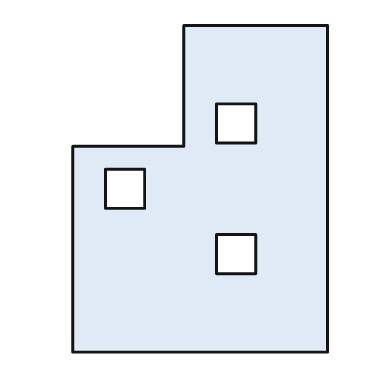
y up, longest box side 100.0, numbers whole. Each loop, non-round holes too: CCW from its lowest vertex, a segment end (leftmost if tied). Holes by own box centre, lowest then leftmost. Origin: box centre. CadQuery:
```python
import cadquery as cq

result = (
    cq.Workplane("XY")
    .moveTo(-39.0, -50.0)
    .lineTo(39.0, -50.0)
    .lineTo(39.0, 50.0)
    .lineTo(-5.0, 50.0)
    .lineTo(-5.0, 13.0)
    .lineTo(-39.0, 13.0)
    .close()
    .moveTo(5.0, -26.0)
    .lineTo(17.0, -26.0)
    .lineTo(17.0, -14.0)
    .lineTo(5.0, -14.0)
    .close()
    .moveTo(-29.0, -6.0)
    .lineTo(-17.0, -6.0)
    .lineTo(-17.0, 6.0)
    .lineTo(-29.0, 6.0)
    .close()
    .moveTo(5.0, 14.0)
    .lineTo(17.0, 14.0)
    .lineTo(17.0, 26.0)
    .lineTo(5.0, 26.0)
    .close()
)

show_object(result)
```